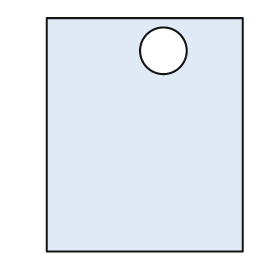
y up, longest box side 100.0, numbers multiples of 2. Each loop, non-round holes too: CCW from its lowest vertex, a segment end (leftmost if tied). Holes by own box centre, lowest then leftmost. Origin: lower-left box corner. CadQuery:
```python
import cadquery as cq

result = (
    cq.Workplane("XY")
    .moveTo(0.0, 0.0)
    .lineTo(84.0, 0.0)
    .lineTo(84.0, 100.0)
    .lineTo(0.0, 100.0)
    .close()
    .moveTo(50.0, 86.0)
    .circle(10.0)
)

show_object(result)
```